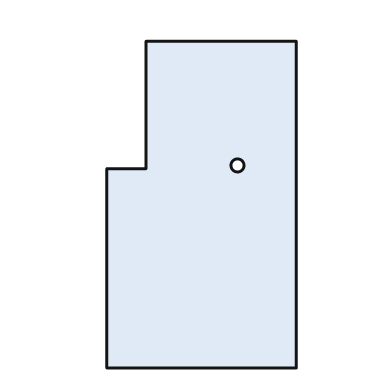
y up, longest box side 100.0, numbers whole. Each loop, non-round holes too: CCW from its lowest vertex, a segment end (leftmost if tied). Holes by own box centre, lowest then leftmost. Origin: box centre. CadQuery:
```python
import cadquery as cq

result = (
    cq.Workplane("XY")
    .moveTo(-29.0, -50.0)
    .lineTo(29.0, -50.0)
    .lineTo(29.0, 50.0)
    .lineTo(-17.0, 50.0)
    .lineTo(-17.0, 11.0)
    .lineTo(-29.0, 11.0)
    .close()
    .moveTo(11.0, 12.0)
    .circle(2.0)
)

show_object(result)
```